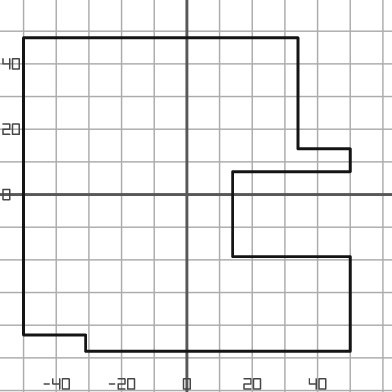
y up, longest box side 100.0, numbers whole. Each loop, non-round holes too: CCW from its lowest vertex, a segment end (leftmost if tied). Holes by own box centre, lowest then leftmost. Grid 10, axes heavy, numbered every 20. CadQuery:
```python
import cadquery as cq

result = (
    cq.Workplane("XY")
    .moveTo(-31.0, -48.0)
    .lineTo(50.0, -48.0)
    .lineTo(50.0, -19.0)
    .lineTo(14.0, -19.0)
    .lineTo(14.0, 7.0)
    .lineTo(50.0, 7.0)
    .lineTo(50.0, 14.0)
    .lineTo(34.0, 14.0)
    .lineTo(34.0, 48.0)
    .lineTo(-50.0, 48.0)
    .lineTo(-50.0, -43.0)
    .lineTo(-31.0, -43.0)
    .close()
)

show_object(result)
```